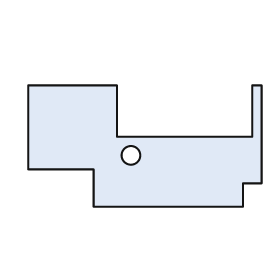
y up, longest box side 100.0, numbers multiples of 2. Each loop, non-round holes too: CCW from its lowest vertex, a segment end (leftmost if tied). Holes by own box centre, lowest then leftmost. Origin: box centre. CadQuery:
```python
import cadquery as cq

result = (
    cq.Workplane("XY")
    .moveTo(-22.0, -26.0)
    .lineTo(42.0, -26.0)
    .lineTo(42.0, -16.0)
    .lineTo(50.0, -16.0)
    .lineTo(50.0, 26.0)
    .lineTo(46.0, 26.0)
    .lineTo(46.0, 4.0)
    .lineTo(-12.0, 4.0)
    .lineTo(-12.0, 26.0)
    .lineTo(-50.0, 26.0)
    .lineTo(-50.0, -10.0)
    .lineTo(-22.0, -10.0)
    .close()
    .moveTo(-6.0, -4.0)
    .circle(4.0)
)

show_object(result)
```